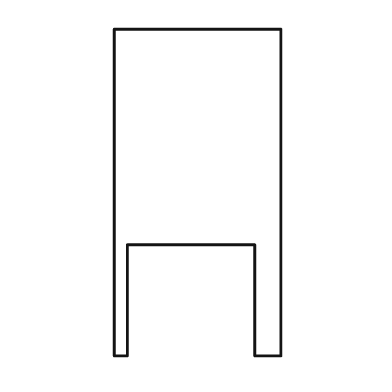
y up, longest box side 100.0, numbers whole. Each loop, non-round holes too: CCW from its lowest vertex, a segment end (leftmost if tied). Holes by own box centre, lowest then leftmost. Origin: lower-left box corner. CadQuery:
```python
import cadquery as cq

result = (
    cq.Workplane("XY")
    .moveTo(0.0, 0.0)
    .lineTo(4.0, 0.0)
    .lineTo(4.0, 34.0)
    .lineTo(43.0, 34.0)
    .lineTo(43.0, 0.0)
    .lineTo(51.0, 0.0)
    .lineTo(51.0, 100.0)
    .lineTo(0.0, 100.0)
    .close()
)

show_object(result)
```